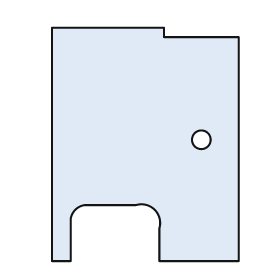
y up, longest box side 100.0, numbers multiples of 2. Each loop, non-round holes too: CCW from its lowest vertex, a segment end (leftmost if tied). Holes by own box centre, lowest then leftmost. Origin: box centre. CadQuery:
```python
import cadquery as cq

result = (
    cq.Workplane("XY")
    .moveTo(-40.0, -50.0)
    .lineTo(-32.0, -50.0)
    .lineTo(-32.0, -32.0)
    .threePointArc((-30.0, -28.0), (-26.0, -26.0))
    .lineTo(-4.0, -26.0)
    .threePointArc((4.0, -28.0), (6.0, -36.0))
    .lineTo(6.0, -50.0)
    .lineTo(40.0, -50.0)
    .lineTo(40.0, 46.0)
    .lineTo(8.0, 46.0)
    .lineTo(8.0, 50.0)
    .lineTo(-40.0, 50.0)
    .close()
    .moveTo(24.0, 2.0)
    .circle(4.0)
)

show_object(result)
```